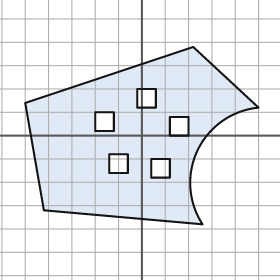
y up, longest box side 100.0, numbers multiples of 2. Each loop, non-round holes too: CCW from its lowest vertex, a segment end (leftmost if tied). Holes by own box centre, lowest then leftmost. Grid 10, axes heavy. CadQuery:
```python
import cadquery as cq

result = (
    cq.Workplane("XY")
    .moveTo(26.0, -38.0)
    .threePointArc((24.0, -6.0), (50.0, 12.0))
    .lineTo(22.0, 38.0)
    .lineTo(-50.0, 14.0)
    .lineTo(-42.0, -32.0)
    .close()
    .moveTo(4.0, -18.0)
    .lineTo(12.0, -18.0)
    .lineTo(12.0, -10.0)
    .lineTo(4.0, -10.0)
    .close()
    .moveTo(-14.0, -16.0)
    .lineTo(-6.0, -16.0)
    .lineTo(-6.0, -8.0)
    .lineTo(-14.0, -8.0)
    .close()
    .moveTo(12.0, 0.0)
    .lineTo(20.0, 0.0)
    .lineTo(20.0, 8.0)
    .lineTo(12.0, 8.0)
    .close()
    .moveTo(-20.0, 2.0)
    .lineTo(-12.0, 2.0)
    .lineTo(-12.0, 10.0)
    .lineTo(-20.0, 10.0)
    .close()
    .moveTo(-2.0, 12.0)
    .lineTo(6.0, 12.0)
    .lineTo(6.0, 20.0)
    .lineTo(-2.0, 20.0)
    .close()
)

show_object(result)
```